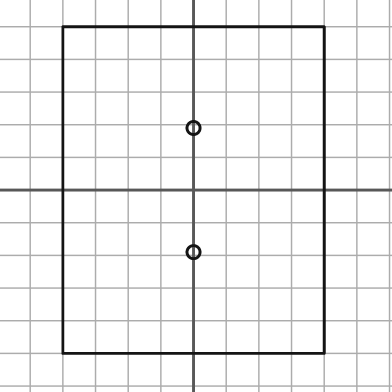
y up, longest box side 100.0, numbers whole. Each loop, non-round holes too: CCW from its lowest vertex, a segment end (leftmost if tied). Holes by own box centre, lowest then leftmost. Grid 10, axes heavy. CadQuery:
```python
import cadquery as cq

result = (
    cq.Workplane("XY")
    .moveTo(-40.0, -50.0)
    .lineTo(40.0, -50.0)
    .lineTo(40.0, 50.0)
    .lineTo(-40.0, 50.0)
    .close()
    .moveTo(0.0, -19.0)
    .circle(2.0)
    .moveTo(0.0, 19.0)
    .circle(2.0)
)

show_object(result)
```